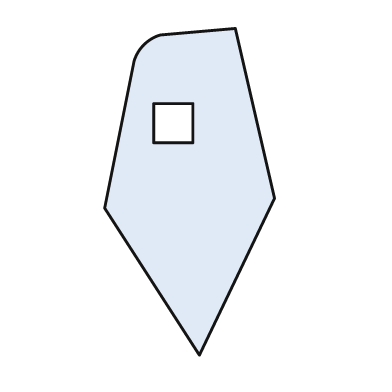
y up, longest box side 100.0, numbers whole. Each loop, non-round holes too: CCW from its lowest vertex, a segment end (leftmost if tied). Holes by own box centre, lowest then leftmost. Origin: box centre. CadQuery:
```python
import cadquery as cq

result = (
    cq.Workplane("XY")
    .moveTo(3.0, -50.0)
    .lineTo(26.0, -2.0)
    .lineTo(14.0, 50.0)
    .lineTo(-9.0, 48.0)
    .threePointArc((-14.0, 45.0), (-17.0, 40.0))
    .lineTo(-26.0, -5.0)
    .close()
    .moveTo(-11.0, 15.0)
    .lineTo(1.0, 15.0)
    .lineTo(1.0, 27.0)
    .lineTo(-11.0, 27.0)
    .close()
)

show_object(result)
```